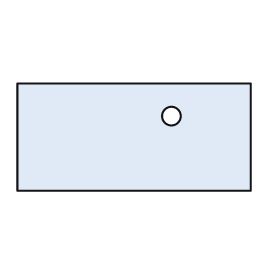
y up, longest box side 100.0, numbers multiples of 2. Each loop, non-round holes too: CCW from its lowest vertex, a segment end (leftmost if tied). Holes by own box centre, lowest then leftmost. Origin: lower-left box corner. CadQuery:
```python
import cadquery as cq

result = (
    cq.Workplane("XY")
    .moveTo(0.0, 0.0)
    .lineTo(100.0, 0.0)
    .lineTo(100.0, 46.0)
    .lineTo(0.0, 46.0)
    .close()
    .moveTo(66.0, 32.0)
    .circle(4.0)
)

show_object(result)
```